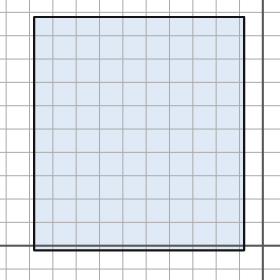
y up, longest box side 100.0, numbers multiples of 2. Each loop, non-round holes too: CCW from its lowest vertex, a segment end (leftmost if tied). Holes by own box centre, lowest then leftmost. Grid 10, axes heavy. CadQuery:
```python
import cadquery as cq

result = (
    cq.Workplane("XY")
    .moveTo(-98.0, -2.0)
    .lineTo(-8.0, -2.0)
    .lineTo(-8.0, 98.0)
    .lineTo(-98.0, 98.0)
    .close()
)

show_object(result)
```